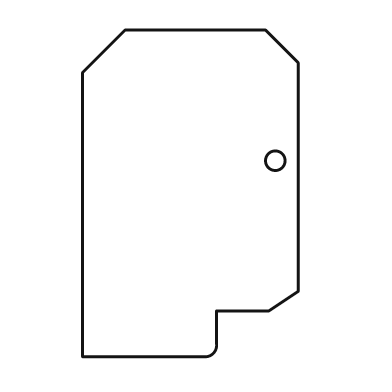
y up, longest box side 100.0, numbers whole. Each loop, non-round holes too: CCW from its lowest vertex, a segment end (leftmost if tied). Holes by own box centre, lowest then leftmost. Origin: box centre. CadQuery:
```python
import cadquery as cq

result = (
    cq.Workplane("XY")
    .moveTo(-33.0, -50.0)
    .lineTo(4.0, -50.0)
    .threePointArc((7.0, -49.0), (8.0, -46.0))
    .lineTo(8.0, -36.0)
    .lineTo(24.0, -36.0)
    .lineTo(33.0, -30.0)
    .lineTo(33.0, 40.0)
    .lineTo(23.0, 50.0)
    .lineTo(-20.0, 50.0)
    .lineTo(-33.0, 37.0)
    .close()
    .moveTo(26.0, 10.0)
    .circle(3.0)
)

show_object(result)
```